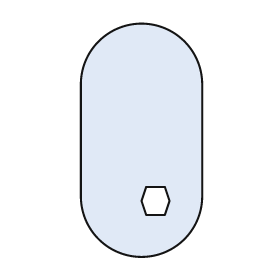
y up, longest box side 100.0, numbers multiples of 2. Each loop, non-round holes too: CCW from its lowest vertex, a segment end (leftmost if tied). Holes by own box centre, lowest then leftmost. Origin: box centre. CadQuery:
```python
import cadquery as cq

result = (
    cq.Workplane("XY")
    .moveTo(-26.0, -24.0)
    .threePointArc((0.0, -50.0), (26.0, -24.0))
    .lineTo(26.0, 24.0)
    .threePointArc((0.0, 50.0), (-26.0, 24.0))
    .close()
    .moveTo(2.0, -32.0)
    .lineTo(10.0, -32.0)
    .lineTo(12.0, -26.0)
    .lineTo(10.0, -20.0)
    .lineTo(2.0, -20.0)
    .lineTo(0.0, -26.0)
    .close()
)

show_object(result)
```